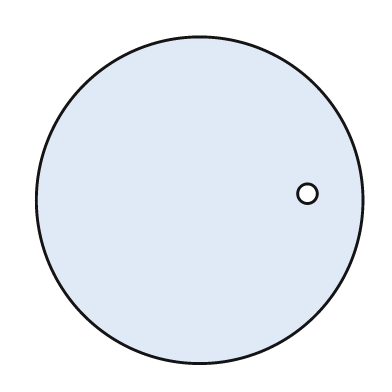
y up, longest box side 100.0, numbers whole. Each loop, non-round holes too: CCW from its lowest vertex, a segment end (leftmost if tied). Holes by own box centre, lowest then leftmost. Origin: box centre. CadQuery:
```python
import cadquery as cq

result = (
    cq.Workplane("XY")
    .moveTo(0.0, 0.0)
    .circle(50.0)
    .moveTo(33.0, 2.0)
    .circle(3.0)
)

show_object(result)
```